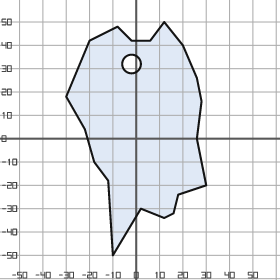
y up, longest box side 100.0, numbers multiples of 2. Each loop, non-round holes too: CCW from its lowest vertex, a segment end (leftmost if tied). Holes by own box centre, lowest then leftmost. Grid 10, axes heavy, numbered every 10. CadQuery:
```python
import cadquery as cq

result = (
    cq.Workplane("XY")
    .moveTo(-10.0, -50.0)
    .lineTo(2.0, -30.0)
    .lineTo(12.0, -34.0)
    .lineTo(16.0, -32.0)
    .lineTo(18.0, -24.0)
    .lineTo(30.0, -20.0)
    .lineTo(26.0, 0.0)
    .lineTo(28.0, 16.0)
    .lineTo(26.0, 26.0)
    .lineTo(20.0, 40.0)
    .lineTo(12.0, 50.0)
    .lineTo(6.0, 42.0)
    .lineTo(-2.0, 42.0)
    .lineTo(-8.0, 48.0)
    .lineTo(-20.0, 42.0)
    .lineTo(-30.0, 18.0)
    .lineTo(-22.0, 4.0)
    .lineTo(-18.0, -10.0)
    .lineTo(-12.0, -18.0)
    .close()
    .moveTo(-2.0, 32.0)
    .circle(4.0)
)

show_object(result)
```